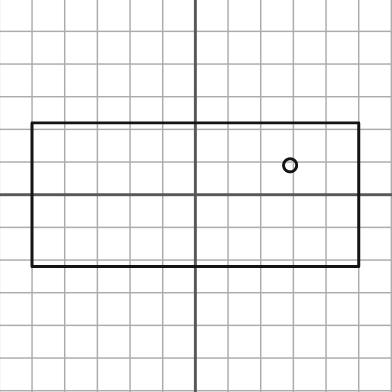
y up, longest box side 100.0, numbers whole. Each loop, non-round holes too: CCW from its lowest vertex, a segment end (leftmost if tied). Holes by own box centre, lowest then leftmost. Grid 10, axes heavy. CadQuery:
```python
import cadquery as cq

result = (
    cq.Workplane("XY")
    .moveTo(-50.0, -22.0)
    .lineTo(50.0, -22.0)
    .lineTo(50.0, 22.0)
    .lineTo(-50.0, 22.0)
    .close()
    .moveTo(29.0, 9.0)
    .circle(2.0)
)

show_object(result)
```